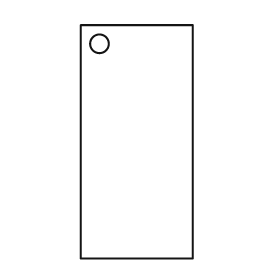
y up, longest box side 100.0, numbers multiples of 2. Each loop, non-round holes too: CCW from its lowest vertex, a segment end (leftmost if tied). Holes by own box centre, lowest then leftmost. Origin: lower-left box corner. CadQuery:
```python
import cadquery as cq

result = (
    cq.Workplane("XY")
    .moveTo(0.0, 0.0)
    .lineTo(48.0, 0.0)
    .lineTo(48.0, 100.0)
    .lineTo(0.0, 100.0)
    .close()
    .moveTo(8.0, 92.0)
    .circle(4.0)
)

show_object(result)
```